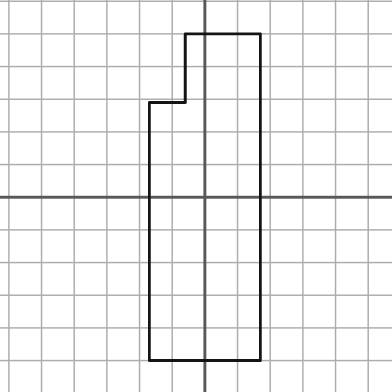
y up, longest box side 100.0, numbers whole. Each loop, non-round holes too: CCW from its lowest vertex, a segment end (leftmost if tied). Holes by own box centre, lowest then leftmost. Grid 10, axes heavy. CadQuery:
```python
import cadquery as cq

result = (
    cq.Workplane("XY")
    .moveTo(-17.0, -50.0)
    .lineTo(17.0, -50.0)
    .lineTo(17.0, 50.0)
    .lineTo(-6.0, 50.0)
    .lineTo(-6.0, 29.0)
    .lineTo(-17.0, 29.0)
    .close()
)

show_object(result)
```